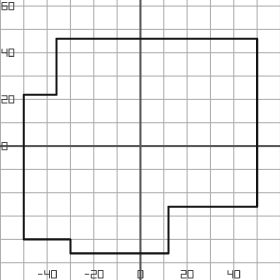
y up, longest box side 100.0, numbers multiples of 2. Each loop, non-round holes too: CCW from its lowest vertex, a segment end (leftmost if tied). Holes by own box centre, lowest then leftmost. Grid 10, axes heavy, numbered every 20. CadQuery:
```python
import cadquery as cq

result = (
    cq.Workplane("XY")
    .moveTo(-30.0, -46.0)
    .lineTo(12.0, -46.0)
    .lineTo(12.0, -26.0)
    .lineTo(50.0, -26.0)
    .lineTo(50.0, 46.0)
    .lineTo(-36.0, 46.0)
    .lineTo(-36.0, 22.0)
    .lineTo(-50.0, 22.0)
    .lineTo(-50.0, -40.0)
    .lineTo(-30.0, -40.0)
    .close()
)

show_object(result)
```